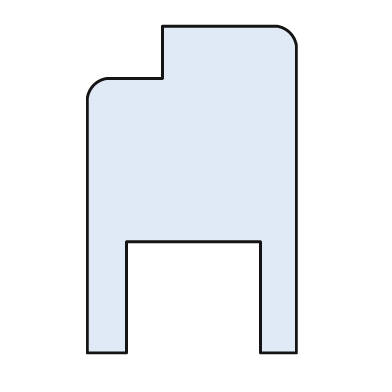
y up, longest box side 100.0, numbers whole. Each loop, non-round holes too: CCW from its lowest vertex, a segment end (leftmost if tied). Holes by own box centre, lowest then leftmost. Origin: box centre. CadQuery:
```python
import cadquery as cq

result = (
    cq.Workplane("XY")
    .moveTo(-32.0, -50.0)
    .lineTo(-20.0, -50.0)
    .lineTo(-20.0, -16.0)
    .lineTo(21.0, -16.0)
    .lineTo(21.0, -50.0)
    .lineTo(32.0, -50.0)
    .lineTo(32.0, 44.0)
    .threePointArc((30.0, 48.0), (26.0, 50.0))
    .lineTo(-9.0, 50.0)
    .lineTo(-9.0, 34.0)
    .lineTo(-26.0, 34.0)
    .threePointArc((-30.0, 32.0), (-32.0, 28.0))
    .close()
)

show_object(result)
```